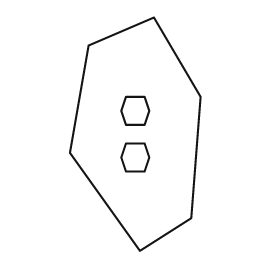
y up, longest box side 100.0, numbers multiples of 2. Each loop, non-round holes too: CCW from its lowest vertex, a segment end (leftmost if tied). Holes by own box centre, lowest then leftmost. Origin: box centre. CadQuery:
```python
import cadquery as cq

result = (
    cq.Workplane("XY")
    .moveTo(2.0, -50.0)
    .lineTo(24.0, -36.0)
    .lineTo(28.0, 16.0)
    .lineTo(8.0, 50.0)
    .lineTo(-20.0, 38.0)
    .lineTo(-28.0, -8.0)
    .close()
    .moveTo(-4.0, -16.0)
    .lineTo(4.0, -16.0)
    .lineTo(6.0, -10.0)
    .lineTo(4.0, -4.0)
    .lineTo(-4.0, -4.0)
    .lineTo(-6.0, -10.0)
    .close()
    .moveTo(-4.0, 4.0)
    .lineTo(4.0, 4.0)
    .lineTo(6.0, 10.0)
    .lineTo(4.0, 16.0)
    .lineTo(-4.0, 16.0)
    .lineTo(-6.0, 10.0)
    .close()
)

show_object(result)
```